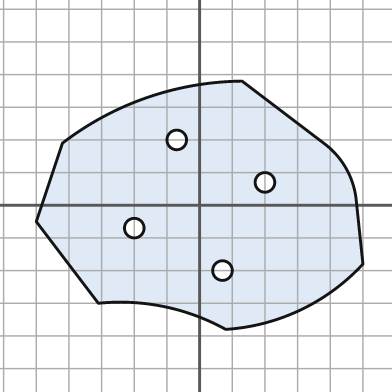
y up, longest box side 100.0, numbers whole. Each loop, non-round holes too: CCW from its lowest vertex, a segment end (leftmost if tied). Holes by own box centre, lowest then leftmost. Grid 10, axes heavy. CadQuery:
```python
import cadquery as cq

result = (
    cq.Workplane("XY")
    .moveTo(8.0, -38.0)
    .threePointArc((31.0, -32.0), (50.0, -18.0))
    .lineTo(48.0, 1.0)
    .threePointArc((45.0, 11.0), (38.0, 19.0))
    .lineTo(13.0, 38.0)
    .threePointArc((-16.0, 33.0), (-42.0, 19.0))
    .lineTo(-50.0, -5.0)
    .lineTo(-31.0, -30.0)
    .threePointArc((-11.0, -31.0), (8.0, -38.0))
    .close()
    .moveTo(7.0, -20.0)
    .circle(3.0)
    .moveTo(-20.0, -7.0)
    .circle(3.0)
    .moveTo(20.0, 7.0)
    .circle(3.0)
    .moveTo(-7.0, 20.0)
    .circle(3.0)
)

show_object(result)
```